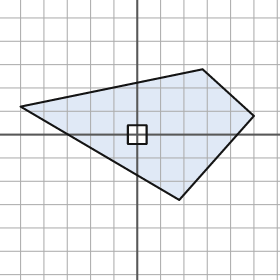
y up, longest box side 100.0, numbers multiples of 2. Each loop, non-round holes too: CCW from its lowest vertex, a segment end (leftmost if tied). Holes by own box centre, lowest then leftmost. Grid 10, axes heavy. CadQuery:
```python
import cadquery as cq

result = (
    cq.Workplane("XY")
    .moveTo(18.0, -28.0)
    .lineTo(50.0, 8.0)
    .lineTo(28.0, 28.0)
    .lineTo(-50.0, 12.0)
    .close()
    .moveTo(-4.0, -4.0)
    .lineTo(4.0, -4.0)
    .lineTo(4.0, 4.0)
    .lineTo(-4.0, 4.0)
    .close()
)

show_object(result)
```